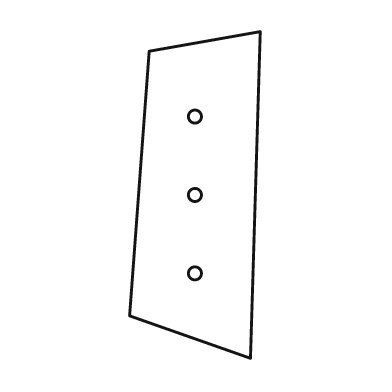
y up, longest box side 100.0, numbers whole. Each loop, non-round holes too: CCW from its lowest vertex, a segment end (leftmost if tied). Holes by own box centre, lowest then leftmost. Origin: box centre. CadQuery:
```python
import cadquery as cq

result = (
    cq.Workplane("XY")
    .moveTo(17.0, -50.0)
    .lineTo(20.0, 50.0)
    .lineTo(-14.0, 44.0)
    .lineTo(-20.0, -37.0)
    .close()
    .moveTo(0.0, -24.0)
    .circle(2.0)
    .moveTo(0.0, 0.0)
    .circle(2.0)
    .moveTo(0.0, 24.0)
    .circle(2.0)
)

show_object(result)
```